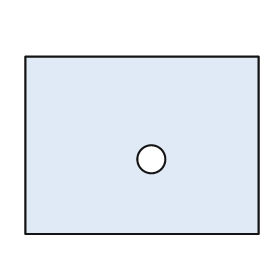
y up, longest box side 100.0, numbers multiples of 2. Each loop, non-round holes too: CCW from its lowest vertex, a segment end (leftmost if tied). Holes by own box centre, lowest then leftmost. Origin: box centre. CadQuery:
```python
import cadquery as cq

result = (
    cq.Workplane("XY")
    .moveTo(-50.0, -38.0)
    .lineTo(50.0, -38.0)
    .lineTo(50.0, 38.0)
    .lineTo(-50.0, 38.0)
    .close()
    .moveTo(4.0, -6.0)
    .circle(6.0)
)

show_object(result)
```